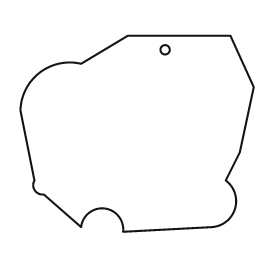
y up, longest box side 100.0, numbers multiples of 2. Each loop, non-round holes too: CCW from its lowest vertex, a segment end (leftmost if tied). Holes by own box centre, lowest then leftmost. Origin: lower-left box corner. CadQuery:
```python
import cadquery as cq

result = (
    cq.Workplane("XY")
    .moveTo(44.0, 0.0)
    .lineTo(82.0, 2.0)
    .threePointArc((92.0, 10.0), (88.0, 22.0))
    .lineTo(94.0, 34.0)
    .lineTo(100.0, 62.0)
    .lineTo(90.0, 84.0)
    .lineTo(46.0, 84.0)
    .lineTo(26.0, 72.0)
    .threePointArc((8.0, 68.0), (0.0, 52.0))
    .lineTo(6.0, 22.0)
    .threePointArc((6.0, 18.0), (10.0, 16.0))
    .lineTo(26.0, 2.0)
    .threePointArc((36.0, 10.0), (44.0, 0.0))
    .close()
    .moveTo(62.0, 78.0)
    .circle(2.0)
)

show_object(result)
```